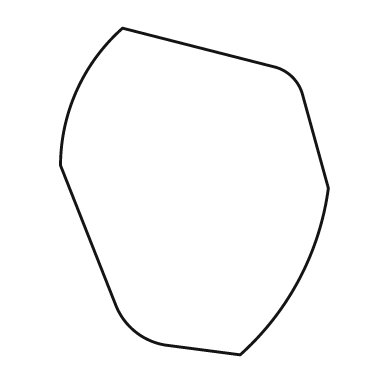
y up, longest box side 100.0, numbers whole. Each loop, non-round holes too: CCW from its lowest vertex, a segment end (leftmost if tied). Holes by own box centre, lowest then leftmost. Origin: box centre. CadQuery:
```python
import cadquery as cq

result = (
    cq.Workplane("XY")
    .moveTo(14.0, -50.0)
    .threePointArc((32.0, -27.0), (41.0, 1.0))
    .lineTo(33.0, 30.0)
    .threePointArc((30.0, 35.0), (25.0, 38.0))
    .lineTo(-22.0, 50.0)
    .threePointArc((-36.0, 31.0), (-41.0, 8.0))
    .lineTo(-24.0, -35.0)
    .threePointArc((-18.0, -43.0), (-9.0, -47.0))
    .close()
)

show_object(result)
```